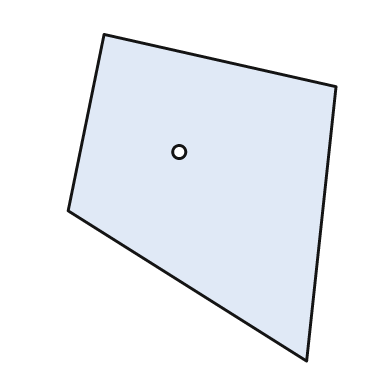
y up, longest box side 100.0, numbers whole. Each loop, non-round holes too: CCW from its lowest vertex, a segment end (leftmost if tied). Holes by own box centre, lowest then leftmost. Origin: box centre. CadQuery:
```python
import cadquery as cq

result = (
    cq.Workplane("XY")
    .moveTo(32.0, -50.0)
    .lineTo(41.0, 34.0)
    .lineTo(-30.0, 50.0)
    .lineTo(-41.0, -4.0)
    .close()
    .moveTo(-7.0, 14.0)
    .circle(2.0)
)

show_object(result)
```